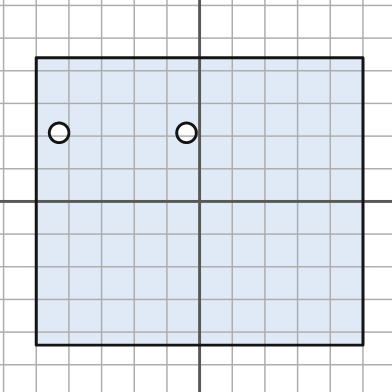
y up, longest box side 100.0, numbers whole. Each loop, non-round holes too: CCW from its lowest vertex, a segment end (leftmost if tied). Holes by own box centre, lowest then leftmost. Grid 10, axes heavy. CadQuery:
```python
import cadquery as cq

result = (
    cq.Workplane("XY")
    .moveTo(-50.0, -44.0)
    .lineTo(50.0, -44.0)
    .lineTo(50.0, 44.0)
    .lineTo(-50.0, 44.0)
    .close()
    .moveTo(-43.0, 21.0)
    .circle(3.0)
    .moveTo(-4.0, 21.0)
    .circle(3.0)
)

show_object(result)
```